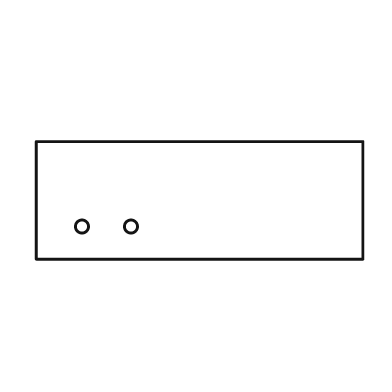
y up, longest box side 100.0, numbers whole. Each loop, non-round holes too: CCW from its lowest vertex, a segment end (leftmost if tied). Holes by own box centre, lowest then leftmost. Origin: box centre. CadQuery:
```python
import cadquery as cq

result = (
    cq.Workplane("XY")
    .moveTo(-50.0, -18.0)
    .lineTo(50.0, -18.0)
    .lineTo(50.0, 18.0)
    .lineTo(-50.0, 18.0)
    .close()
    .moveTo(-36.0, -8.0)
    .circle(2.0)
    .moveTo(-21.0, -8.0)
    .circle(2.0)
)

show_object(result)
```